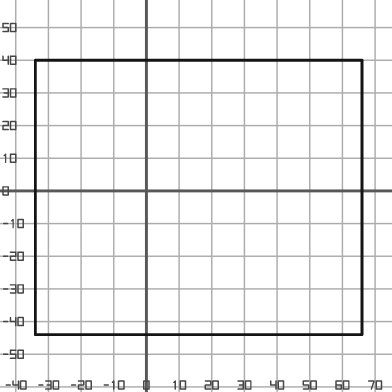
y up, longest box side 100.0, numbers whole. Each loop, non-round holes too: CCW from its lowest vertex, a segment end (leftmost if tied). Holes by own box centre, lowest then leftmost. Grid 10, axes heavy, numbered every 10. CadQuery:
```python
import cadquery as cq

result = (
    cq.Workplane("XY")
    .moveTo(-34.0, -44.0)
    .lineTo(66.0, -44.0)
    .lineTo(66.0, 40.0)
    .lineTo(-34.0, 40.0)
    .close()
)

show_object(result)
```